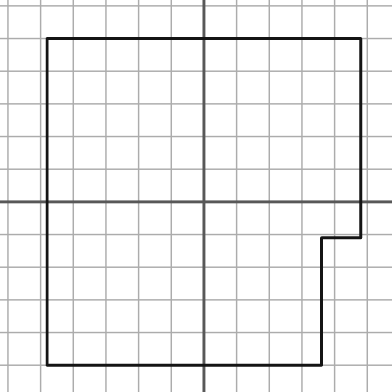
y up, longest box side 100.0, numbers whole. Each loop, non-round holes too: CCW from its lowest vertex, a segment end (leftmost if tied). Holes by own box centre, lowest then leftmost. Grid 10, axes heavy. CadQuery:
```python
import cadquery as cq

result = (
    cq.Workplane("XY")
    .moveTo(-48.0, -50.0)
    .lineTo(36.0, -50.0)
    .lineTo(36.0, -11.0)
    .lineTo(48.0, -11.0)
    .lineTo(48.0, 50.0)
    .lineTo(-48.0, 50.0)
    .close()
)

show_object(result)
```